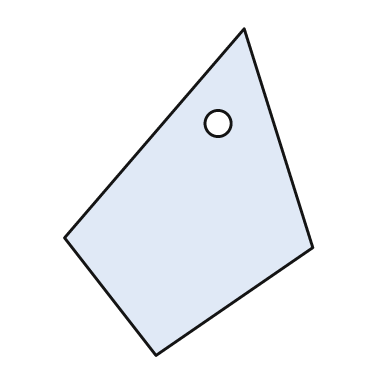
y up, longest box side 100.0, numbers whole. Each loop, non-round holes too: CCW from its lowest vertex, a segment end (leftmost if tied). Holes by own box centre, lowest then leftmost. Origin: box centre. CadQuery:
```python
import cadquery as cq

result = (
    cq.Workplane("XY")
    .moveTo(-10.0, -50.0)
    .lineTo(38.0, -17.0)
    .lineTo(17.0, 50.0)
    .lineTo(-38.0, -14.0)
    .close()
    .moveTo(9.0, 21.0)
    .circle(4.0)
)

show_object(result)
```